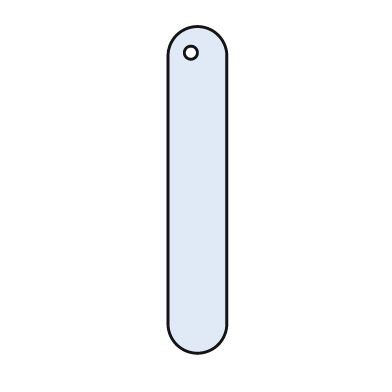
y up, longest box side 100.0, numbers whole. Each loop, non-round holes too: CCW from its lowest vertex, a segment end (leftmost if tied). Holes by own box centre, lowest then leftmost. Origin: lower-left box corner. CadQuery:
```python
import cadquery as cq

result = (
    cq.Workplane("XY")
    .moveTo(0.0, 9.0)
    .threePointArc((9.0, 0.0), (18.0, 9.0))
    .lineTo(18.0, 91.0)
    .threePointArc((9.0, 100.0), (0.0, 91.0))
    .close()
    .moveTo(7.0, 92.0)
    .circle(2.0)
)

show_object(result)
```